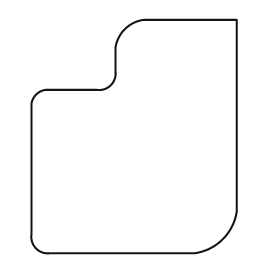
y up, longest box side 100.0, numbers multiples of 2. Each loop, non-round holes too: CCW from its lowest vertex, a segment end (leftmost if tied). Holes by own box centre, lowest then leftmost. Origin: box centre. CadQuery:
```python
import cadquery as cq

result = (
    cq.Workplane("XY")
    .moveTo(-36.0, -50.0)
    .lineTo(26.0, -50.0)
    .threePointArc((38.0, -44.0), (44.0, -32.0))
    .lineTo(44.0, 50.0)
    .lineTo(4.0, 50.0)
    .threePointArc((-4.0, 46.0), (-8.0, 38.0))
    .lineTo(-8.0, 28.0)
    .threePointArc((-10.0, 22.0), (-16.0, 20.0))
    .lineTo(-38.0, 20.0)
    .threePointArc((-42.0, 18.0), (-44.0, 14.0))
    .lineTo(-44.0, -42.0)
    .threePointArc((-42.0, -48.0), (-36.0, -50.0))
    .close()
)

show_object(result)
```